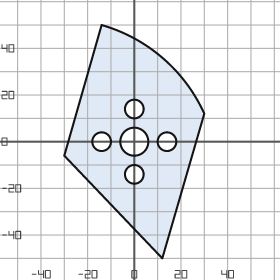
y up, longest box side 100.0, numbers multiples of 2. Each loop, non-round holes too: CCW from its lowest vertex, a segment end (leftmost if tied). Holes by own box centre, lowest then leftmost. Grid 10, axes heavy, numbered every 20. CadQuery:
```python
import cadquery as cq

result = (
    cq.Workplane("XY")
    .moveTo(12.0, -50.0)
    .lineTo(30.0, 12.0)
    .threePointArc((12.0, 36.0), (-14.0, 50.0))
    .lineTo(-30.0, -6.0)
    .close()
    .moveTo(0.0, -14.0)
    .circle(4.0)
    .moveTo(-14.0, 0.0)
    .circle(4.0)
    .moveTo(0.0, 0.0)
    .circle(6.0)
    .moveTo(14.0, 0.0)
    .circle(4.0)
    .moveTo(0.0, 14.0)
    .circle(4.0)
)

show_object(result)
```